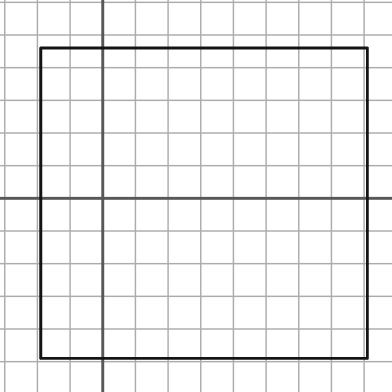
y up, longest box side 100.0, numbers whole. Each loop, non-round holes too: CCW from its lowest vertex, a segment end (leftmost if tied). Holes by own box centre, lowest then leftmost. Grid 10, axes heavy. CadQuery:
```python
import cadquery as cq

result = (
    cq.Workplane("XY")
    .moveTo(-19.0, -49.0)
    .lineTo(81.0, -49.0)
    .lineTo(81.0, 46.0)
    .lineTo(-19.0, 46.0)
    .close()
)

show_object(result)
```